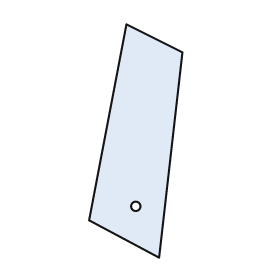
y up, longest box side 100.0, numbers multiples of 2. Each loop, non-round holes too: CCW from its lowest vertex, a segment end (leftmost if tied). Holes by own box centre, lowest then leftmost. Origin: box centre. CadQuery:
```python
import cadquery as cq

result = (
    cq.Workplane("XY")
    .moveTo(10.0, -50.0)
    .lineTo(20.0, 38.0)
    .lineTo(-4.0, 50.0)
    .lineTo(-20.0, -34.0)
    .close()
    .moveTo(0.0, -28.0)
    .circle(2.0)
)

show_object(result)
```